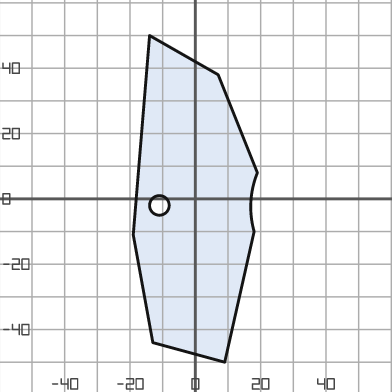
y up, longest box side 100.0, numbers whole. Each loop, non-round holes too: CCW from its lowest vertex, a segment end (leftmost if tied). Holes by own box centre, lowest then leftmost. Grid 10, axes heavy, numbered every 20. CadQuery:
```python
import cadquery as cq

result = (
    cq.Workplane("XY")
    .moveTo(9.0, -50.0)
    .lineTo(18.0, -10.0)
    .threePointArc((17.0, -1.0), (19.0, 8.0))
    .lineTo(7.0, 38.0)
    .lineTo(-14.0, 50.0)
    .lineTo(-19.0, -11.0)
    .lineTo(-13.0, -44.0)
    .close()
    .moveTo(-11.0, -2.0)
    .circle(3.0)
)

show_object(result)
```